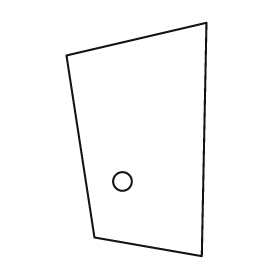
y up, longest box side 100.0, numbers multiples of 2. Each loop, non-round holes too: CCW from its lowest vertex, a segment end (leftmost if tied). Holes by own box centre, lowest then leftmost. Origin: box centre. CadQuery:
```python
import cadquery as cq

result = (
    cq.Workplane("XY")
    .moveTo(28.0, -50.0)
    .lineTo(30.0, 50.0)
    .lineTo(-30.0, 36.0)
    .lineTo(-18.0, -42.0)
    .close()
    .moveTo(-6.0, -18.0)
    .circle(4.0)
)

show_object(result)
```